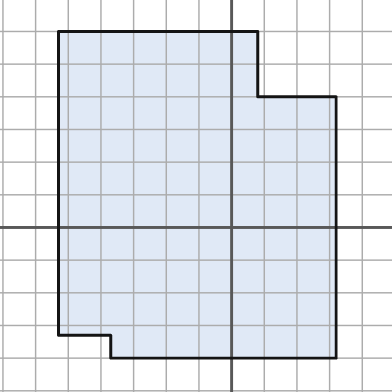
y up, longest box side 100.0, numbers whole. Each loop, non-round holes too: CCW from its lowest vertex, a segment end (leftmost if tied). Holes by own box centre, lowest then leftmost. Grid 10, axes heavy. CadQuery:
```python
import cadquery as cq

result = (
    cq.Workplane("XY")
    .moveTo(-37.0, -40.0)
    .lineTo(32.0, -40.0)
    .lineTo(32.0, 40.0)
    .lineTo(8.0, 40.0)
    .lineTo(8.0, 60.0)
    .lineTo(-53.0, 60.0)
    .lineTo(-53.0, -33.0)
    .lineTo(-37.0, -33.0)
    .close()
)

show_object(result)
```